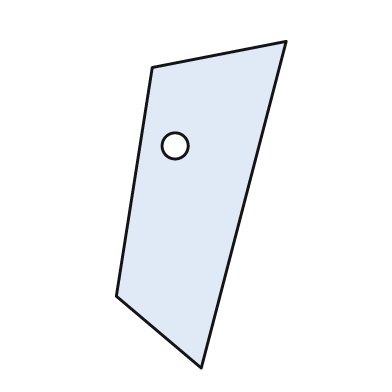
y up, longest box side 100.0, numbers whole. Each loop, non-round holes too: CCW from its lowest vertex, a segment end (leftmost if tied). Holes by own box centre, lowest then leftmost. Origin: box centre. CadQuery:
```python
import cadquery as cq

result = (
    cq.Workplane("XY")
    .moveTo(0.0, -50.0)
    .lineTo(26.0, 50.0)
    .lineTo(-15.0, 42.0)
    .lineTo(-26.0, -28.0)
    .close()
    .moveTo(-8.0, 18.0)
    .circle(4.0)
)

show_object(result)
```